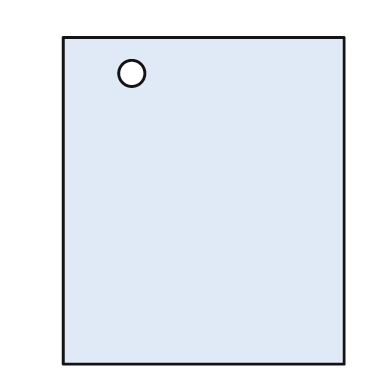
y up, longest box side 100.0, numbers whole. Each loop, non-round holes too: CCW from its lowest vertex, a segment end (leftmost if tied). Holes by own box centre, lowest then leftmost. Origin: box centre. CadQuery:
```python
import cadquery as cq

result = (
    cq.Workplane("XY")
    .moveTo(-43.0, -50.0)
    .lineTo(43.0, -50.0)
    .lineTo(43.0, 50.0)
    .lineTo(-43.0, 50.0)
    .close()
    .moveTo(-22.0, 39.0)
    .circle(4.0)
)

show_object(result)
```